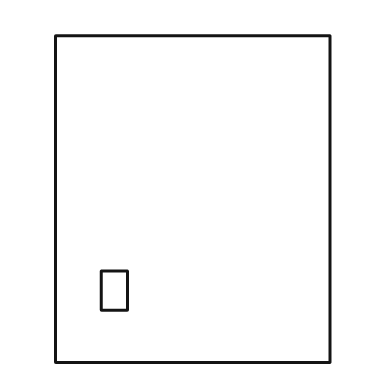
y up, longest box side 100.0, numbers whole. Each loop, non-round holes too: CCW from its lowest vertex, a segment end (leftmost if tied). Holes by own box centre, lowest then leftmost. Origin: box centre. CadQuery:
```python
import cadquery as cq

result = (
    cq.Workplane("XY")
    .moveTo(-42.0, -50.0)
    .lineTo(42.0, -50.0)
    .lineTo(42.0, 50.0)
    .lineTo(-42.0, 50.0)
    .close()
    .moveTo(-28.0, -34.0)
    .lineTo(-20.0, -34.0)
    .lineTo(-20.0, -22.0)
    .lineTo(-28.0, -22.0)
    .close()
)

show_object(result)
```